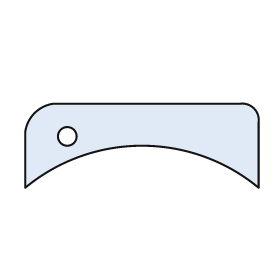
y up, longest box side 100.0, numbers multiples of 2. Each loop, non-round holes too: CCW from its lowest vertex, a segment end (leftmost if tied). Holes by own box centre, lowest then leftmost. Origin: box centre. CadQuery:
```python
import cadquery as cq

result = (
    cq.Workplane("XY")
    .moveTo(-50.0, -18.0)
    .threePointArc((0.0, 0.0), (50.0, -18.0))
    .lineTo(50.0, 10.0)
    .threePointArc((48.0, 16.0), (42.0, 18.0))
    .lineTo(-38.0, 18.0)
    .threePointArc((-46.0, 14.0), (-50.0, 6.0))
    .close()
    .moveTo(-32.0, 4.0)
    .circle(4.0)
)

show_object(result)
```